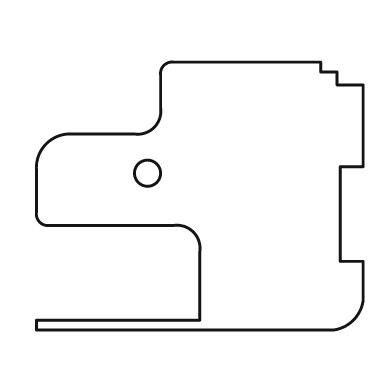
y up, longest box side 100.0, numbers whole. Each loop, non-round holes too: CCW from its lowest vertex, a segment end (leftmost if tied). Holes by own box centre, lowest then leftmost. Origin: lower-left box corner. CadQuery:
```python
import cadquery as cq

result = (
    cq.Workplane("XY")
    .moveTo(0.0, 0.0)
    .lineTo(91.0, 0.0)
    .threePointArc((97.0, 3.0), (100.0, 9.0))
    .lineTo(100.0, 21.0)
    .lineTo(93.0, 21.0)
    .lineTo(93.0, 50.0)
    .lineTo(100.0, 50.0)
    .lineTo(100.0, 75.0)
    .lineTo(92.0, 75.0)
    .lineTo(92.0, 79.0)
    .lineTo(87.0, 79.0)
    .lineTo(87.0, 82.0)
    .lineTo(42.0, 82.0)
    .threePointArc((39.0, 81.0), (38.0, 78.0))
    .lineTo(38.0, 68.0)
    .threePointArc((36.0, 62.0), (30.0, 60.0))
    .lineTo(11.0, 60.0)
    .threePointArc((3.0, 57.0), (0.0, 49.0))
    .lineTo(0.0, 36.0)
    .threePointArc((1.0, 33.0), (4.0, 32.0))
    .lineTo(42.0, 32.0)
    .threePointArc((48.0, 30.0), (50.0, 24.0))
    .lineTo(50.0, 3.0)
    .lineTo(0.0, 3.0)
    .close()
    .moveTo(34.0, 48.0)
    .circle(4.0)
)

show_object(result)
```